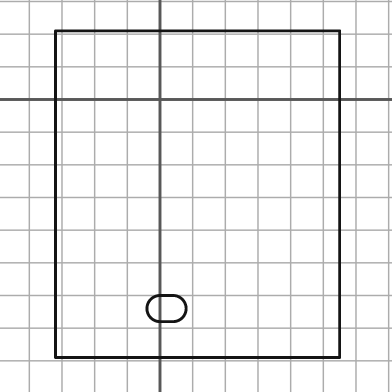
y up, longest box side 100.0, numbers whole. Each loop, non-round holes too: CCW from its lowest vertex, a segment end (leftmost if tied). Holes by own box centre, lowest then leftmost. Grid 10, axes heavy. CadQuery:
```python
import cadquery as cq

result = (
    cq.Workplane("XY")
    .moveTo(-32.0, -79.0)
    .lineTo(55.0, -79.0)
    .lineTo(55.0, 21.0)
    .lineTo(-32.0, 21.0)
    .close()
    .moveTo(0.0, -68.0)
    .lineTo(4.0, -68.0)
    .threePointArc((8.0, -64.0), (4.0, -60.0))
    .lineTo(0.0, -60.0)
    .threePointArc((-4.0, -64.0), (0.0, -68.0))
    .close()
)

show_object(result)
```